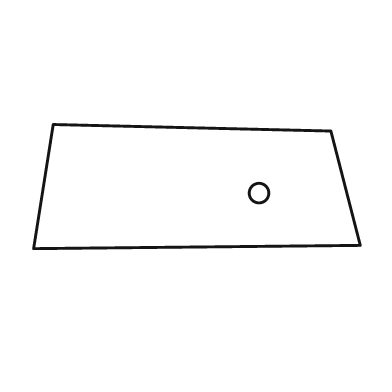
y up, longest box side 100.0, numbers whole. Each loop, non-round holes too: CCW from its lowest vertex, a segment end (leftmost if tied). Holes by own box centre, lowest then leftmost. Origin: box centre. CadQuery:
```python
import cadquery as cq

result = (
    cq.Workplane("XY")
    .moveTo(-50.0, -19.0)
    .lineTo(50.0, -18.0)
    .lineTo(41.0, 17.0)
    .lineTo(-44.0, 19.0)
    .close()
    .moveTo(19.0, -2.0)
    .circle(3.0)
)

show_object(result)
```